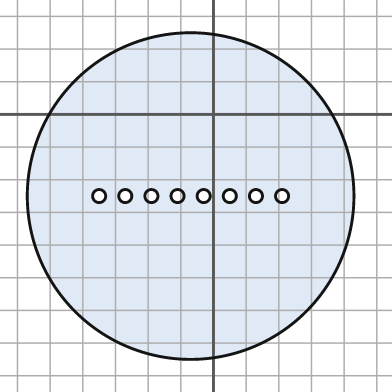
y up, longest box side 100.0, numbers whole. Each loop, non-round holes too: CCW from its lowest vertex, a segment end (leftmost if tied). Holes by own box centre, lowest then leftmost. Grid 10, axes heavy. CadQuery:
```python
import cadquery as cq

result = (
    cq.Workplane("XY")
    .moveTo(-7.0, -25.0)
    .circle(50.0)
    .moveTo(-35.0, -25.0)
    .circle(2.0)
    .moveTo(-27.0, -25.0)
    .circle(2.0)
    .moveTo(-19.0, -25.0)
    .circle(2.0)
    .moveTo(-11.0, -25.0)
    .circle(2.0)
    .moveTo(-3.0, -25.0)
    .circle(2.0)
    .moveTo(5.0, -25.0)
    .circle(2.0)
    .moveTo(13.0, -25.0)
    .circle(2.0)
    .moveTo(21.0, -25.0)
    .circle(2.0)
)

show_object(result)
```